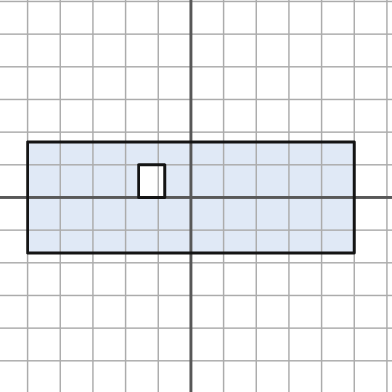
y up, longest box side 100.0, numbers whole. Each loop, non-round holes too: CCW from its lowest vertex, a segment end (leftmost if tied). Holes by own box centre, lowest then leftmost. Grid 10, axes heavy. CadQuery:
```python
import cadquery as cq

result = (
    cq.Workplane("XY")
    .moveTo(-50.0, -17.0)
    .lineTo(50.0, -17.0)
    .lineTo(50.0, 17.0)
    .lineTo(-50.0, 17.0)
    .close()
    .moveTo(-16.0, 0.0)
    .lineTo(-8.0, 0.0)
    .lineTo(-8.0, 10.0)
    .lineTo(-16.0, 10.0)
    .close()
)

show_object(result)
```